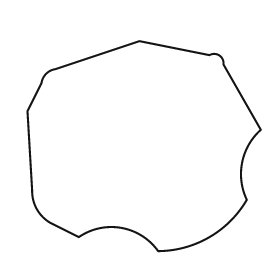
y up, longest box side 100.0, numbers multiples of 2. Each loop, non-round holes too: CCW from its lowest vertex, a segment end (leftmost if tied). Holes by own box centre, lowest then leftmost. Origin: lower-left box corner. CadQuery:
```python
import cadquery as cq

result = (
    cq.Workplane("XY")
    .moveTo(56.0, 0.0)
    .threePointArc((78.0, 6.0), (94.0, 22.0))
    .threePointArc((92.0, 38.0), (100.0, 52.0))
    .lineTo(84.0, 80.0)
    .threePointArc((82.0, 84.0), (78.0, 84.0))
    .lineTo(48.0, 90.0)
    .lineTo(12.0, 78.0)
    .threePointArc((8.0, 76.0), (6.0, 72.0))
    .lineTo(0.0, 60.0)
    .lineTo(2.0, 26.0)
    .threePointArc((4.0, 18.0), (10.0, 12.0))
    .lineTo(22.0, 6.0)
    .threePointArc((40.0, 10.0), (56.0, 0.0))
    .close()
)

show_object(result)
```